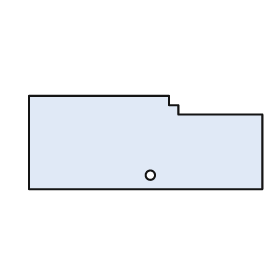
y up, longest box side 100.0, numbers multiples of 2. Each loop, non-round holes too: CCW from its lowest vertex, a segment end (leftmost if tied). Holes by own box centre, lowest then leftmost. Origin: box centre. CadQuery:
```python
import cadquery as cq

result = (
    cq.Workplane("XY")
    .moveTo(-50.0, -20.0)
    .lineTo(50.0, -20.0)
    .lineTo(50.0, 12.0)
    .lineTo(14.0, 12.0)
    .lineTo(14.0, 16.0)
    .lineTo(10.0, 16.0)
    .lineTo(10.0, 20.0)
    .lineTo(-50.0, 20.0)
    .close()
    .moveTo(2.0, -14.0)
    .circle(2.0)
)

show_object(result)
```